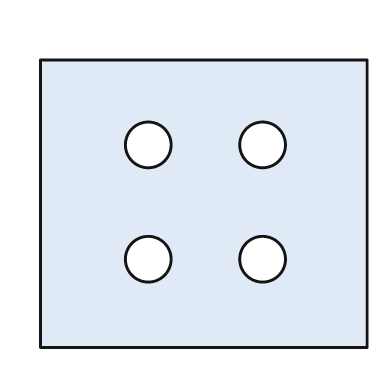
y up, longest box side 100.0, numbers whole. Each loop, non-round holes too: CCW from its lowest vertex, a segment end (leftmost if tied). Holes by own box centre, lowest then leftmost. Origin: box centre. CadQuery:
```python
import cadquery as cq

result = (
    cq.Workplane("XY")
    .moveTo(-50.0, -44.0)
    .lineTo(50.0, -44.0)
    .lineTo(50.0, 44.0)
    .lineTo(-50.0, 44.0)
    .close()
    .moveTo(-17.0, -17.0)
    .circle(7.0)
    .moveTo(18.0, -17.0)
    .circle(7.0)
    .moveTo(-17.0, 18.0)
    .circle(7.0)
    .moveTo(18.0, 18.0)
    .circle(7.0)
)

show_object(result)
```